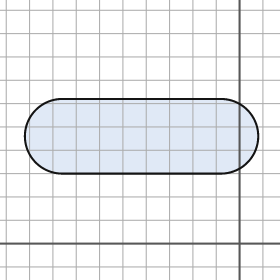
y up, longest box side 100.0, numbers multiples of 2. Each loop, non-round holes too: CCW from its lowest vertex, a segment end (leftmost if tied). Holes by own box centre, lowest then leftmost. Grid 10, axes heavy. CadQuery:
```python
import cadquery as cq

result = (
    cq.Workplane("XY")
    .moveTo(-76.0, 30.0)
    .lineTo(-8.0, 30.0)
    .threePointArc((8.0, 46.0), (-8.0, 62.0))
    .lineTo(-76.0, 62.0)
    .threePointArc((-92.0, 46.0), (-76.0, 30.0))
    .close()
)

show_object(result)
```